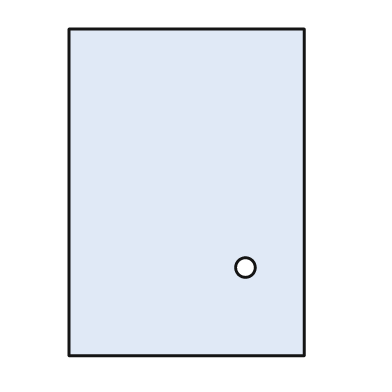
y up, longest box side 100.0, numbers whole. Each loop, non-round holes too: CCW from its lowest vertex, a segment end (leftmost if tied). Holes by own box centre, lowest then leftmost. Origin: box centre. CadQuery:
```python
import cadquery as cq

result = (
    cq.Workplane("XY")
    .moveTo(-36.0, -50.0)
    .lineTo(36.0, -50.0)
    .lineTo(36.0, 50.0)
    .lineTo(-36.0, 50.0)
    .close()
    .moveTo(18.0, -23.0)
    .circle(3.0)
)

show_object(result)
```